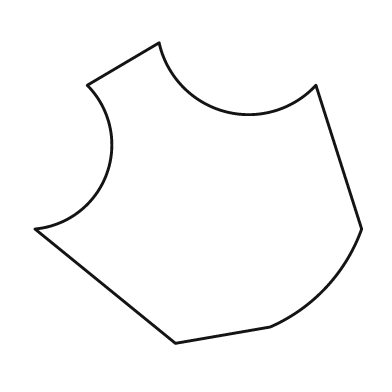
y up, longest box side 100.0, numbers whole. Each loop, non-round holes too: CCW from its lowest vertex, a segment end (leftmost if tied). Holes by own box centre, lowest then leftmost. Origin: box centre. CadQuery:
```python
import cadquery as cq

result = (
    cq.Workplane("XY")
    .moveTo(-7.0, -46.0)
    .lineTo(22.0, -41.0)
    .threePointArc((39.0, -29.0), (50.0, -11.0))
    .lineTo(36.0, 33.0)
    .threePointArc((8.0, 25.0), (-12.0, 46.0))
    .lineTo(-34.0, 33.0)
    .threePointArc((-28.0, 6.0), (-50.0, -11.0))
    .close()
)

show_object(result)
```